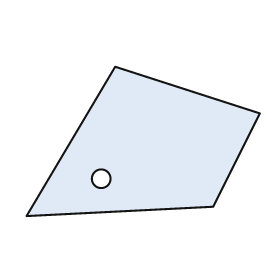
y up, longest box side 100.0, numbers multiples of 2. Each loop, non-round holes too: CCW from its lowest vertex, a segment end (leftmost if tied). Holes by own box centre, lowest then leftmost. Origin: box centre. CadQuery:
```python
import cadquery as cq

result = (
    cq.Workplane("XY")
    .moveTo(-50.0, -32.0)
    .lineTo(30.0, -28.0)
    .lineTo(50.0, 12.0)
    .lineTo(-12.0, 32.0)
    .close()
    .moveTo(-18.0, -16.0)
    .circle(4.0)
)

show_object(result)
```